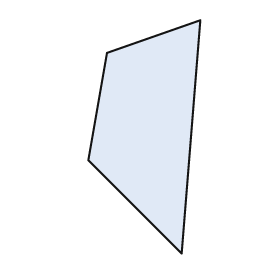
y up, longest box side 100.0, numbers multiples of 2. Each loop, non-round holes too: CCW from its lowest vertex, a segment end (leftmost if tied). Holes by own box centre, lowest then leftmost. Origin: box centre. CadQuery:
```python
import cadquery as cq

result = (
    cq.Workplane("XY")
    .moveTo(16.0, -50.0)
    .lineTo(24.0, 50.0)
    .lineTo(-16.0, 36.0)
    .lineTo(-24.0, -10.0)
    .close()
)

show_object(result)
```